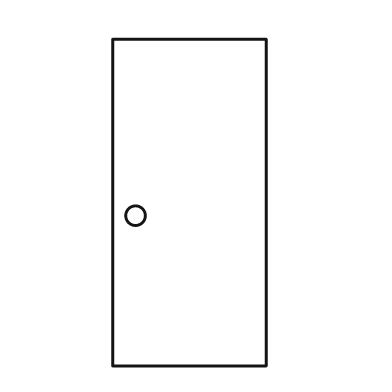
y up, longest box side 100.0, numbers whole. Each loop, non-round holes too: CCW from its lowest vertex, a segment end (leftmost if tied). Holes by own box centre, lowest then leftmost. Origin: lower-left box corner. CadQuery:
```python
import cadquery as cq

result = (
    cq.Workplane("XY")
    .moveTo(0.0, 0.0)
    .lineTo(47.0, 0.0)
    .lineTo(47.0, 100.0)
    .lineTo(0.0, 100.0)
    .close()
    .moveTo(7.0, 46.0)
    .circle(3.0)
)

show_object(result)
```